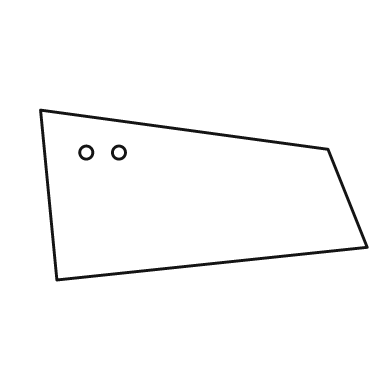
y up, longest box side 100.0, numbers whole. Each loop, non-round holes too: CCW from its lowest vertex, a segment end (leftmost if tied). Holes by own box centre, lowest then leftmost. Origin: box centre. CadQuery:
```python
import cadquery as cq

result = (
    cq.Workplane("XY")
    .moveTo(-45.0, -26.0)
    .lineTo(50.0, -16.0)
    .lineTo(38.0, 14.0)
    .lineTo(-50.0, 26.0)
    .close()
    .moveTo(-36.0, 13.0)
    .circle(2.0)
    .moveTo(-26.0, 13.0)
    .circle(2.0)
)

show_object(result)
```